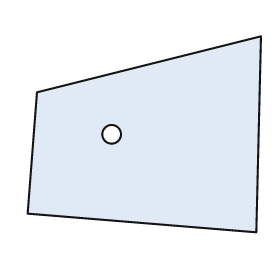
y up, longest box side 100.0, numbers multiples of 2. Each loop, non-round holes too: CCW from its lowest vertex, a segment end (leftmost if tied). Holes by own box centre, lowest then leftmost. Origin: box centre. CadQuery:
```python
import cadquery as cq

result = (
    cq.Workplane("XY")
    .moveTo(48.0, -42.0)
    .lineTo(50.0, 42.0)
    .lineTo(-46.0, 18.0)
    .lineTo(-50.0, -34.0)
    .close()
    .moveTo(-14.0, 0.0)
    .circle(4.0)
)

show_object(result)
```